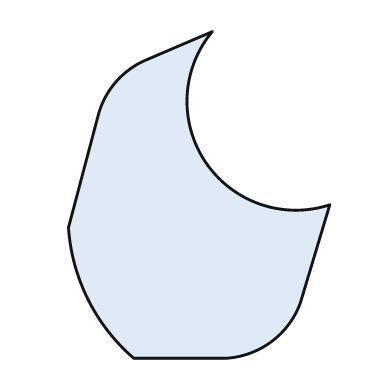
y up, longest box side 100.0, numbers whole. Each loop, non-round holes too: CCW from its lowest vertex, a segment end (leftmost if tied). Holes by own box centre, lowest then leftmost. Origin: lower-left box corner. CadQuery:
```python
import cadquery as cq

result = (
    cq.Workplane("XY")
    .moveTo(20.0, 0.0)
    .lineTo(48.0, 0.0)
    .threePointArc((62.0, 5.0), (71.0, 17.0))
    .lineTo(80.0, 47.0)
    .threePointArc((42.0, 60.0), (44.0, 100.0))
    .lineTo(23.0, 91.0)
    .threePointArc((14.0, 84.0), (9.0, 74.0))
    .lineTo(0.0, 40.0)
    .threePointArc((6.0, 18.0), (20.0, 0.0))
    .close()
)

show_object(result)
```